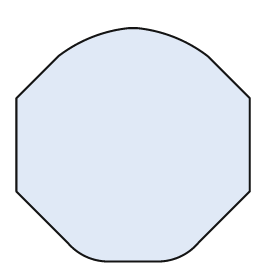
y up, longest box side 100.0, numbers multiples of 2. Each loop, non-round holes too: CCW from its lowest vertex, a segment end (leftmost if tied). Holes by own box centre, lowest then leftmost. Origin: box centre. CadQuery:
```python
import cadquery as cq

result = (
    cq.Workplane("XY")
    .moveTo(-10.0, -50.0)
    .lineTo(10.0, -50.0)
    .threePointArc((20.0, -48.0), (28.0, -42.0))
    .lineTo(50.0, -20.0)
    .lineTo(50.0, 20.0)
    .lineTo(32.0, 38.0)
    .threePointArc((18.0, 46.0), (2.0, 50.0))
    .lineTo(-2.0, 50.0)
    .threePointArc((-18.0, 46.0), (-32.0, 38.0))
    .lineTo(-50.0, 20.0)
    .lineTo(-50.0, -20.0)
    .lineTo(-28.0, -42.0)
    .threePointArc((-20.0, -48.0), (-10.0, -50.0))
    .close()
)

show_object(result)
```